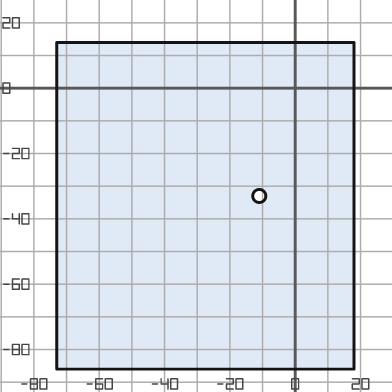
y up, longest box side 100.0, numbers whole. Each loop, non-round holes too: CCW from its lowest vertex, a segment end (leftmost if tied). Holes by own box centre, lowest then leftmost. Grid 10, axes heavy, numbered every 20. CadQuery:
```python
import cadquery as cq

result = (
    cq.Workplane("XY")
    .moveTo(-73.0, -86.0)
    .lineTo(18.0, -86.0)
    .lineTo(18.0, 14.0)
    .lineTo(-73.0, 14.0)
    .close()
    .moveTo(-11.0, -33.0)
    .circle(2.0)
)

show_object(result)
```